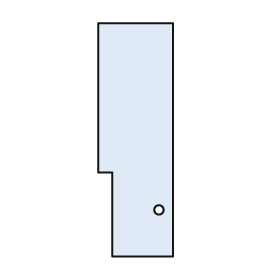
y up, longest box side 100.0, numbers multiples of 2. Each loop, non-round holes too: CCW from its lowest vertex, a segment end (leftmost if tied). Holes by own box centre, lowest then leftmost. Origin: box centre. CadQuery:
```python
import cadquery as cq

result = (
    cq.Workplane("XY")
    .moveTo(-10.0, -50.0)
    .lineTo(16.0, -50.0)
    .lineTo(16.0, 50.0)
    .lineTo(-16.0, 50.0)
    .lineTo(-16.0, -14.0)
    .lineTo(-10.0, -14.0)
    .close()
    .moveTo(10.0, -30.0)
    .circle(2.0)
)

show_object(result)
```